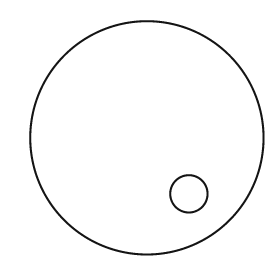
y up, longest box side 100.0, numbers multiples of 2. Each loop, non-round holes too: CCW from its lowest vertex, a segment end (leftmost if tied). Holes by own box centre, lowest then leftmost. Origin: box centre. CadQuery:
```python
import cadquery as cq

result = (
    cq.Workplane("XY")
    .moveTo(0.0, 0.0)
    .circle(50.0)
    .moveTo(18.0, -24.0)
    .circle(8.0)
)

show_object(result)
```